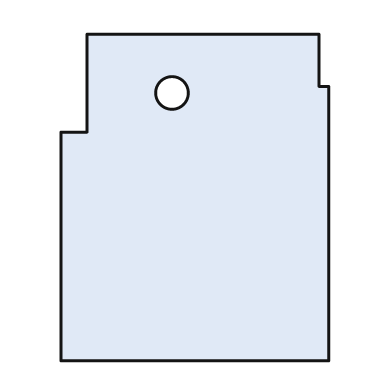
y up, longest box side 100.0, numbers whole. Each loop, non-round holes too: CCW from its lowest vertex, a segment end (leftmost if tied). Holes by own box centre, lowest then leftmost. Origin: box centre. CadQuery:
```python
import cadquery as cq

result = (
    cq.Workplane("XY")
    .moveTo(-41.0, -50.0)
    .lineTo(41.0, -50.0)
    .lineTo(41.0, 34.0)
    .lineTo(38.0, 34.0)
    .lineTo(38.0, 50.0)
    .lineTo(-33.0, 50.0)
    .lineTo(-33.0, 20.0)
    .lineTo(-41.0, 20.0)
    .close()
    .moveTo(-7.0, 32.0)
    .circle(5.0)
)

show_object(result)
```